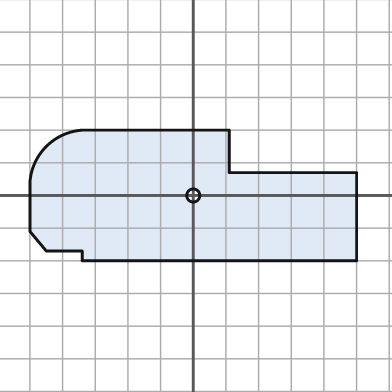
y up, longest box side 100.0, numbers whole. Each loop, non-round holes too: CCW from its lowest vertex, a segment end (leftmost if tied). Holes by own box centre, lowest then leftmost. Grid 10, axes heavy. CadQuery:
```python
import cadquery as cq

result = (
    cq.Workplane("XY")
    .moveTo(-34.0, -20.0)
    .lineTo(50.0, -20.0)
    .lineTo(50.0, 7.0)
    .lineTo(11.0, 7.0)
    .lineTo(11.0, 20.0)
    .lineTo(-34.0, 20.0)
    .threePointArc((-45.0, 15.0), (-50.0, 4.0))
    .lineTo(-50.0, -11.0)
    .lineTo(-45.0, -17.0)
    .lineTo(-34.0, -17.0)
    .close()
    .moveTo(0.0, 0.0)
    .circle(2.0)
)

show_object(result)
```